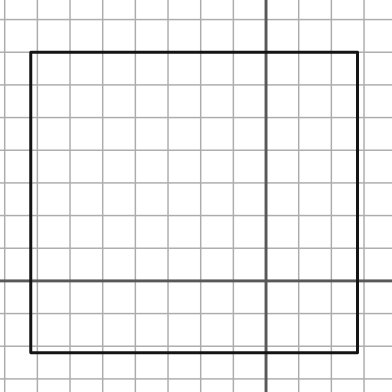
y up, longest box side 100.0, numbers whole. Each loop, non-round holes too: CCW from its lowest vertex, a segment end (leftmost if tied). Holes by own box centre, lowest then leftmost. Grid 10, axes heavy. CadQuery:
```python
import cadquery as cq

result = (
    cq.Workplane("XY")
    .moveTo(-72.0, -22.0)
    .lineTo(28.0, -22.0)
    .lineTo(28.0, 70.0)
    .lineTo(-72.0, 70.0)
    .close()
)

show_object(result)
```